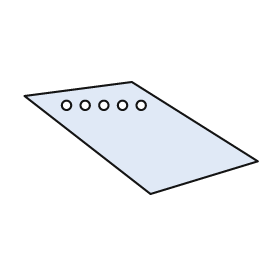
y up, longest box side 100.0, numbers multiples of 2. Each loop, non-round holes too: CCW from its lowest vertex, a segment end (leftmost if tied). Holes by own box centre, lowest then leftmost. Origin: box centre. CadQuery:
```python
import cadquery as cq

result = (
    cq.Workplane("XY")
    .moveTo(4.0, -24.0)
    .lineTo(50.0, -10.0)
    .lineTo(-4.0, 24.0)
    .lineTo(-50.0, 18.0)
    .close()
    .moveTo(-32.0, 14.0)
    .circle(2.0)
    .moveTo(-24.0, 14.0)
    .circle(2.0)
    .moveTo(-16.0, 14.0)
    .circle(2.0)
    .moveTo(-8.0, 14.0)
    .circle(2.0)
    .moveTo(0.0, 14.0)
    .circle(2.0)
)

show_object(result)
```